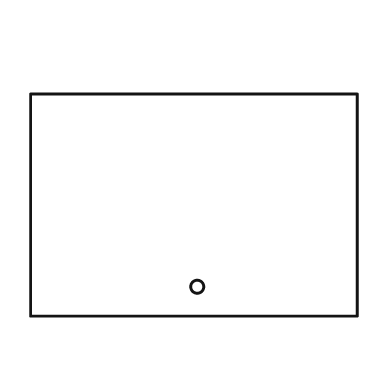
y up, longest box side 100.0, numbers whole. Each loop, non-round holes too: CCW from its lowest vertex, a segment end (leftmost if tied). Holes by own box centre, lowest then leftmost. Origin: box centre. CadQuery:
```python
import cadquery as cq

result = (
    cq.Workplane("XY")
    .moveTo(-50.0, -34.0)
    .lineTo(50.0, -34.0)
    .lineTo(50.0, 34.0)
    .lineTo(-50.0, 34.0)
    .close()
    .moveTo(1.0, -25.0)
    .circle(2.0)
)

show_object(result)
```